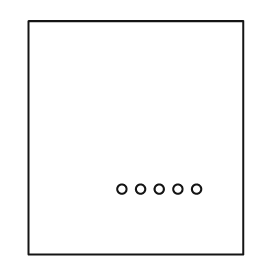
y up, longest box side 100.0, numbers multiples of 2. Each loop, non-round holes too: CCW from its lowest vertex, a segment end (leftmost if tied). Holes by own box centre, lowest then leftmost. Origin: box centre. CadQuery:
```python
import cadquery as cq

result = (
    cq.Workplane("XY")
    .moveTo(-46.0, -50.0)
    .lineTo(46.0, -50.0)
    .lineTo(46.0, 50.0)
    .lineTo(-46.0, 50.0)
    .close()
    .moveTo(-6.0, -22.0)
    .circle(2.0)
    .moveTo(2.0, -22.0)
    .circle(2.0)
    .moveTo(10.0, -22.0)
    .circle(2.0)
    .moveTo(18.0, -22.0)
    .circle(2.0)
    .moveTo(26.0, -22.0)
    .circle(2.0)
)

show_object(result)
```